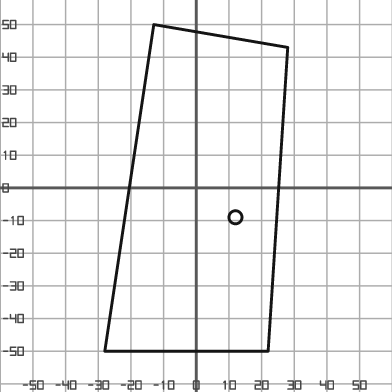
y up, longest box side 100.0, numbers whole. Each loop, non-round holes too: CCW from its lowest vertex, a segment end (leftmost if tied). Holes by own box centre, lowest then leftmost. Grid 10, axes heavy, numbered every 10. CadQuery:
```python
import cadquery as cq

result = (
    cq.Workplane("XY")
    .moveTo(-28.0, -50.0)
    .lineTo(22.0, -50.0)
    .lineTo(28.0, 43.0)
    .lineTo(-13.0, 50.0)
    .close()
    .moveTo(12.0, -9.0)
    .circle(2.0)
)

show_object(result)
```